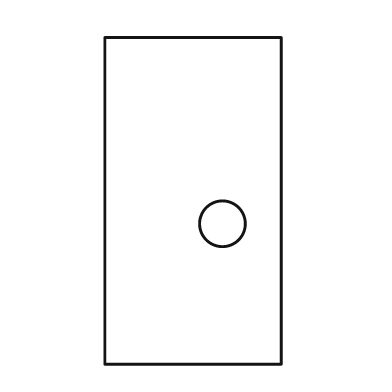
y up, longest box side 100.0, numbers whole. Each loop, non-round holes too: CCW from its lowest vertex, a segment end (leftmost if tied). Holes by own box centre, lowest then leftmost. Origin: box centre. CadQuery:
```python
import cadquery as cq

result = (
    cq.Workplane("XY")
    .moveTo(-27.0, -50.0)
    .lineTo(27.0, -50.0)
    .lineTo(27.0, 50.0)
    .lineTo(-27.0, 50.0)
    .close()
    .moveTo(9.0, -7.0)
    .circle(7.0)
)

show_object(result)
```